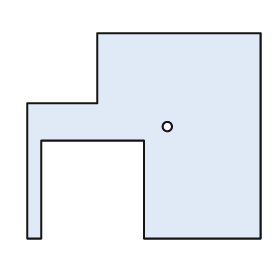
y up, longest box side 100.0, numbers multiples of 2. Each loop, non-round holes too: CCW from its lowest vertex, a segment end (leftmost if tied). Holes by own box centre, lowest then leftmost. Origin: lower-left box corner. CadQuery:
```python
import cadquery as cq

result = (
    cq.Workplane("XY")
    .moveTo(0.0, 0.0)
    .lineTo(6.0, 0.0)
    .lineTo(6.0, 42.0)
    .lineTo(50.0, 42.0)
    .lineTo(50.0, 0.0)
    .lineTo(100.0, 0.0)
    .lineTo(100.0, 88.0)
    .lineTo(30.0, 88.0)
    .lineTo(30.0, 58.0)
    .lineTo(0.0, 58.0)
    .close()
    .moveTo(60.0, 48.0)
    .circle(2.0)
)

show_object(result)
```